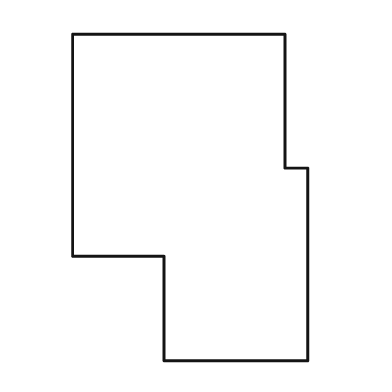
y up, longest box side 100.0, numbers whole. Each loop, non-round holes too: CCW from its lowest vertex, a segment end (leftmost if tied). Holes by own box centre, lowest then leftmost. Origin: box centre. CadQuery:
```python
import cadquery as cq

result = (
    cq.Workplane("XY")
    .moveTo(-8.0, -50.0)
    .lineTo(36.0, -50.0)
    .lineTo(36.0, 9.0)
    .lineTo(29.0, 9.0)
    .lineTo(29.0, 50.0)
    .lineTo(-36.0, 50.0)
    .lineTo(-36.0, -18.0)
    .lineTo(-8.0, -18.0)
    .close()
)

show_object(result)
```